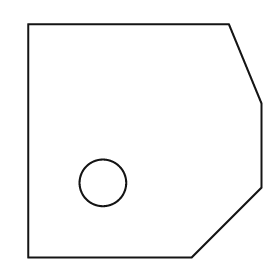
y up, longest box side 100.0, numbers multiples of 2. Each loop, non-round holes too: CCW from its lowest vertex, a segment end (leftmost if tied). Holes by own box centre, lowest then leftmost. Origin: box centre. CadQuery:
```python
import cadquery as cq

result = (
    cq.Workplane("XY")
    .moveTo(-50.0, -50.0)
    .lineTo(20.0, -50.0)
    .lineTo(50.0, -20.0)
    .lineTo(50.0, 16.0)
    .lineTo(36.0, 50.0)
    .lineTo(-50.0, 50.0)
    .close()
    .moveTo(-18.0, -18.0)
    .circle(10.0)
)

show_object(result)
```